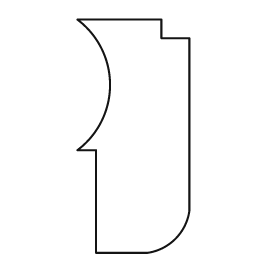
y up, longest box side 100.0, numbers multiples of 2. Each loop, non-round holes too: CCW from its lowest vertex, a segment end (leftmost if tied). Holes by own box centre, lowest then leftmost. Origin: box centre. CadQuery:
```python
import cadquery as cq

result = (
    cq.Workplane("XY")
    .moveTo(-16.0, -50.0)
    .lineTo(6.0, -50.0)
    .threePointArc((18.0, -44.0), (24.0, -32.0))
    .lineTo(24.0, 42.0)
    .lineTo(12.0, 42.0)
    .lineTo(12.0, 50.0)
    .lineTo(-24.0, 50.0)
    .threePointArc((-10.0, 22.0), (-24.0, -6.0))
    .lineTo(-16.0, -6.0)
    .close()
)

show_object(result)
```